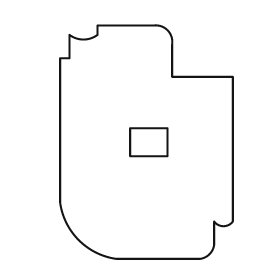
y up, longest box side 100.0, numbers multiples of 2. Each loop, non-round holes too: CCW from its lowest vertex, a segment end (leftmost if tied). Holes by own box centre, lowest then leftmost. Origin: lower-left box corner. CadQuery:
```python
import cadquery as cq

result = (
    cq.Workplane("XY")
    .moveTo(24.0, 0.0)
    .lineTo(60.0, 0.0)
    .threePointArc((64.0, 2.0), (66.0, 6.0))
    .lineTo(66.0, 16.0)
    .threePointArc((70.0, 14.0), (74.0, 16.0))
    .lineTo(74.0, 78.0)
    .lineTo(48.0, 78.0)
    .lineTo(48.0, 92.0)
    .threePointArc((46.0, 98.0), (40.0, 100.0))
    .lineTo(16.0, 100.0)
    .lineTo(16.0, 96.0)
    .threePointArc((10.0, 94.0), (4.0, 96.0))
    .lineTo(4.0, 86.0)
    .lineTo(0.0, 86.0)
    .lineTo(0.0, 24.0)
    .threePointArc((8.0, 8.0), (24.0, 0.0))
    .close()
    .moveTo(30.0, 44.0)
    .lineTo(46.0, 44.0)
    .lineTo(46.0, 56.0)
    .lineTo(30.0, 56.0)
    .close()
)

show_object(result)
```